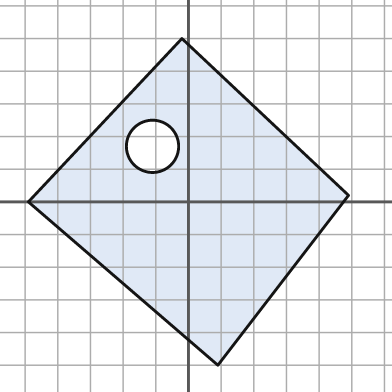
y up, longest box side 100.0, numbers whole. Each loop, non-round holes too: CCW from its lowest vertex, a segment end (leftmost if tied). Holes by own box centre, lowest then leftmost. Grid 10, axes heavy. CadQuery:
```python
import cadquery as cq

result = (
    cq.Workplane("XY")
    .moveTo(9.0, -50.0)
    .lineTo(49.0, 2.0)
    .lineTo(-2.0, 50.0)
    .lineTo(-49.0, 0.0)
    .close()
    .moveTo(-11.0, 17.0)
    .circle(8.0)
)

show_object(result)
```